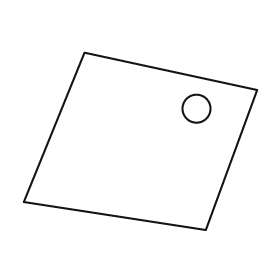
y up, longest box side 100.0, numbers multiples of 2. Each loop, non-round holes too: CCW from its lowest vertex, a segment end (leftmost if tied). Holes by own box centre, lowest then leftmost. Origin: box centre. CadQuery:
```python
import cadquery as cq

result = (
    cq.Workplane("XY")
    .moveTo(28.0, -38.0)
    .lineTo(50.0, 22.0)
    .lineTo(-24.0, 38.0)
    .lineTo(-50.0, -26.0)
    .close()
    .moveTo(24.0, 14.0)
    .circle(6.0)
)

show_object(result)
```